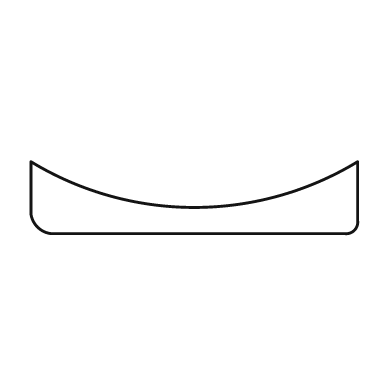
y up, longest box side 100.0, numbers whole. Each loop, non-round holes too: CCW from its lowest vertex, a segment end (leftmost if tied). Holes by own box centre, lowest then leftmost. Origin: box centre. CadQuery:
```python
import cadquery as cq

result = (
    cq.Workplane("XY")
    .moveTo(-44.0, -11.0)
    .lineTo(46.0, -11.0)
    .threePointArc((49.0, -10.0), (50.0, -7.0))
    .lineTo(50.0, 11.0)
    .threePointArc((0.0, -3.0), (-50.0, 11.0))
    .lineTo(-50.0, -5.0)
    .threePointArc((-48.0, -9.0), (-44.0, -11.0))
    .close()
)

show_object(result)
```